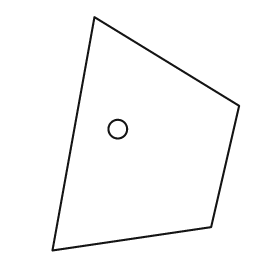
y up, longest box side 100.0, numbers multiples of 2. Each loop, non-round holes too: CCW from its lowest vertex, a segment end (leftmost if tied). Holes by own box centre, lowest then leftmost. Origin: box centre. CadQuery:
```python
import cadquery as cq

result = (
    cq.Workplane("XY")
    .moveTo(-40.0, -50.0)
    .lineTo(28.0, -40.0)
    .lineTo(40.0, 12.0)
    .lineTo(-22.0, 50.0)
    .close()
    .moveTo(-12.0, 2.0)
    .circle(4.0)
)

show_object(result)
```